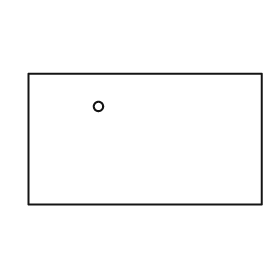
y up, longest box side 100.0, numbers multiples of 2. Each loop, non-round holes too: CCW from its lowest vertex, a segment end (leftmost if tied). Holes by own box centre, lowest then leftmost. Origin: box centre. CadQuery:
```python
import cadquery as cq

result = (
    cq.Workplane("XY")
    .moveTo(-50.0, -28.0)
    .lineTo(50.0, -28.0)
    .lineTo(50.0, 28.0)
    .lineTo(-50.0, 28.0)
    .close()
    .moveTo(-20.0, 14.0)
    .circle(2.0)
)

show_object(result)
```